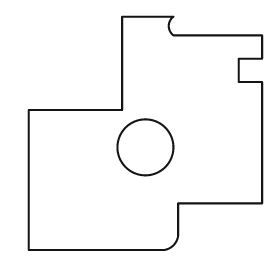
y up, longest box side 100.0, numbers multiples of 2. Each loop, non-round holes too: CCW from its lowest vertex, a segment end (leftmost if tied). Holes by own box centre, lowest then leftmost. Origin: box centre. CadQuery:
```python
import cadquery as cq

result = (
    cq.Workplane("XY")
    .moveTo(-50.0, -50.0)
    .lineTo(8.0, -50.0)
    .threePointArc((12.0, -48.0), (14.0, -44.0))
    .lineTo(14.0, -30.0)
    .lineTo(50.0, -30.0)
    .lineTo(50.0, 22.0)
    .lineTo(40.0, 22.0)
    .lineTo(40.0, 32.0)
    .lineTo(50.0, 32.0)
    .lineTo(50.0, 42.0)
    .lineTo(12.0, 42.0)
    .threePointArc((10.0, 46.0), (12.0, 50.0))
    .lineTo(-10.0, 50.0)
    .lineTo(-10.0, 10.0)
    .lineTo(-50.0, 10.0)
    .close()
    .moveTo(0.0, -6.0)
    .circle(12.0)
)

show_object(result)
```